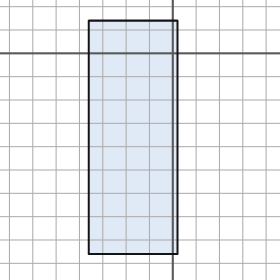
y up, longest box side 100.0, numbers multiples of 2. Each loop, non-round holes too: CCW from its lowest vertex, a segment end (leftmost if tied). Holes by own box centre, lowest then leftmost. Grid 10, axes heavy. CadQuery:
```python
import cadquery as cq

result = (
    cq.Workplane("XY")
    .moveTo(-36.0, -86.0)
    .lineTo(2.0, -86.0)
    .lineTo(2.0, 14.0)
    .lineTo(-36.0, 14.0)
    .close()
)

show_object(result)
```